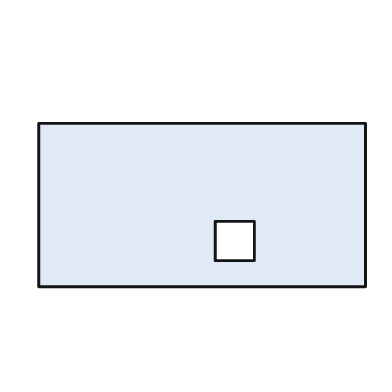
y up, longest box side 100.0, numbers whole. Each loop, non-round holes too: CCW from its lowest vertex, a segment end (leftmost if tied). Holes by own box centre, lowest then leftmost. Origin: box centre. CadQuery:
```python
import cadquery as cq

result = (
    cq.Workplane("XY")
    .moveTo(-50.0, -25.0)
    .lineTo(50.0, -25.0)
    .lineTo(50.0, 25.0)
    .lineTo(-50.0, 25.0)
    .close()
    .moveTo(4.0, -17.0)
    .lineTo(16.0, -17.0)
    .lineTo(16.0, -5.0)
    .lineTo(4.0, -5.0)
    .close()
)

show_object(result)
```